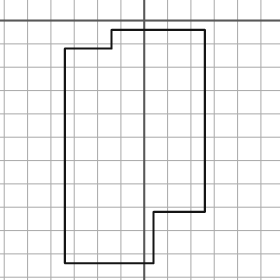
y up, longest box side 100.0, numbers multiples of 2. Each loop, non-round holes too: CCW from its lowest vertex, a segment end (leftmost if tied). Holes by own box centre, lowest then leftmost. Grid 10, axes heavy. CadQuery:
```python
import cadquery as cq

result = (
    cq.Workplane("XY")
    .moveTo(-34.0, -104.0)
    .lineTo(4.0, -104.0)
    .lineTo(4.0, -82.0)
    .lineTo(26.0, -82.0)
    .lineTo(26.0, -4.0)
    .lineTo(-14.0, -4.0)
    .lineTo(-14.0, -12.0)
    .lineTo(-34.0, -12.0)
    .close()
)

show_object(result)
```